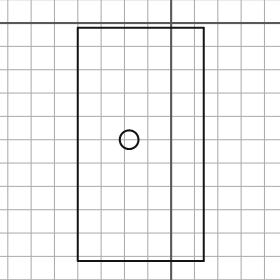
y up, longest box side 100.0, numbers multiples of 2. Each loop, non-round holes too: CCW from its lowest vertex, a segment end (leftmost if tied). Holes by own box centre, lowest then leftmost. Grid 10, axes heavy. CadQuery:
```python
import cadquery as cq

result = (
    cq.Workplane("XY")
    .moveTo(-40.0, -102.0)
    .lineTo(14.0, -102.0)
    .lineTo(14.0, -2.0)
    .lineTo(-40.0, -2.0)
    .close()
    .moveTo(-18.0, -50.0)
    .circle(4.0)
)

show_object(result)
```